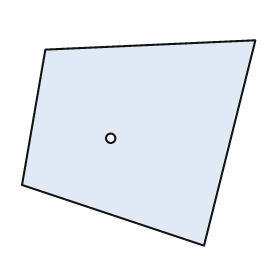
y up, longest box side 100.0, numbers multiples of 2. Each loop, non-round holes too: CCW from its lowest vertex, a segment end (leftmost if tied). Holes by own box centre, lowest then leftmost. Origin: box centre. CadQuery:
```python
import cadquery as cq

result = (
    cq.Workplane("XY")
    .moveTo(28.0, -44.0)
    .lineTo(50.0, 44.0)
    .lineTo(-40.0, 40.0)
    .lineTo(-50.0, -18.0)
    .close()
    .moveTo(-12.0, 2.0)
    .circle(2.0)
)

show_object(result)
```